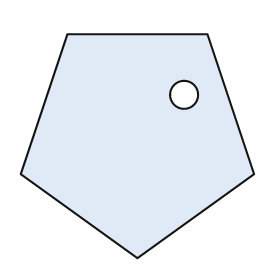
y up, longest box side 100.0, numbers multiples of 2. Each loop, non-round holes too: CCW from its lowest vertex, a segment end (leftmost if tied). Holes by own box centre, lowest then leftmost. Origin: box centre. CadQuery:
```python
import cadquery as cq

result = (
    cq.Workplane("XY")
    .moveTo(0.0, -48.0)
    .lineTo(50.0, -12.0)
    .lineTo(30.0, 48.0)
    .lineTo(-30.0, 48.0)
    .lineTo(-50.0, -12.0)
    .close()
    .moveTo(20.0, 22.0)
    .circle(6.0)
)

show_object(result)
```